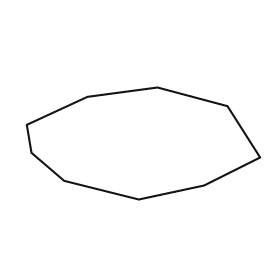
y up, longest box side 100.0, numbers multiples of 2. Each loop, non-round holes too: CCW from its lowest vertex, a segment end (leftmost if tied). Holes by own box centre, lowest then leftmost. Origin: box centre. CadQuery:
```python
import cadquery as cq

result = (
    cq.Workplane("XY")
    .moveTo(-2.0, -24.0)
    .lineTo(26.0, -18.0)
    .lineTo(50.0, -6.0)
    .lineTo(36.0, 16.0)
    .lineTo(6.0, 24.0)
    .lineTo(-24.0, 20.0)
    .lineTo(-50.0, 8.0)
    .lineTo(-48.0, -4.0)
    .lineTo(-34.0, -16.0)
    .close()
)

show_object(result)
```